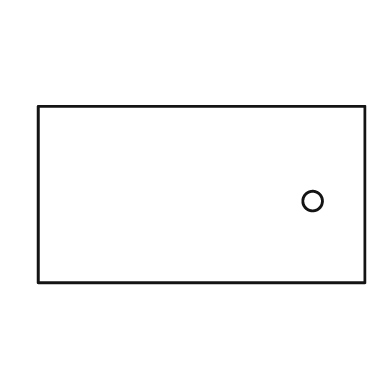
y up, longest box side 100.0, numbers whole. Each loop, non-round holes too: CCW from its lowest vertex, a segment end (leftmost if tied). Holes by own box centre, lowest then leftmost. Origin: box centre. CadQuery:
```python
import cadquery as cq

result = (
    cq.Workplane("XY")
    .moveTo(-50.0, -27.0)
    .lineTo(50.0, -27.0)
    .lineTo(50.0, 27.0)
    .lineTo(-50.0, 27.0)
    .close()
    .moveTo(34.0, -2.0)
    .circle(3.0)
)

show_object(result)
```